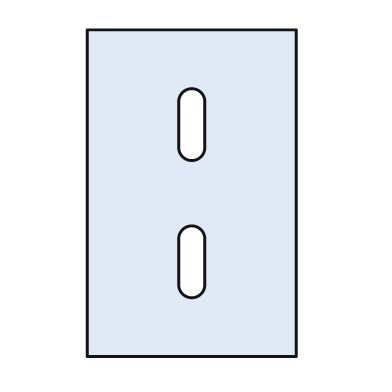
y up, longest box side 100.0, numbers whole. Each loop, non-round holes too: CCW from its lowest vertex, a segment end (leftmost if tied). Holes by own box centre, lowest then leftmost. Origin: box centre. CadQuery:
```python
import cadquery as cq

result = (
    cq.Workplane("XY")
    .moveTo(-32.0, -50.0)
    .lineTo(32.0, -50.0)
    .lineTo(32.0, 50.0)
    .lineTo(-32.0, 50.0)
    .close()
    .moveTo(-4.0, -28.0)
    .threePointArc((0.0, -32.0), (4.0, -28.0))
    .lineTo(4.0, -14.0)
    .threePointArc((0.0, -10.0), (-4.0, -14.0))
    .close()
    .moveTo(-4.0, 14.0)
    .threePointArc((0.0, 10.0), (4.0, 14.0))
    .lineTo(4.0, 28.0)
    .threePointArc((0.0, 32.0), (-4.0, 28.0))
    .close()
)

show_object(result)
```